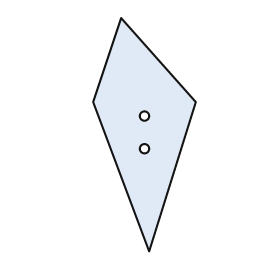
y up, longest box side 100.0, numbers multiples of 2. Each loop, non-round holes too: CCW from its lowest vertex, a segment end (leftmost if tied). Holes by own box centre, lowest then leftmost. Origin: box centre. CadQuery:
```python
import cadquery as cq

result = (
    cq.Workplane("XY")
    .moveTo(2.0, -50.0)
    .lineTo(22.0, 14.0)
    .lineTo(-10.0, 50.0)
    .lineTo(-22.0, 14.0)
    .close()
    .moveTo(0.0, -6.0)
    .circle(2.0)
    .moveTo(0.0, 8.0)
    .circle(2.0)
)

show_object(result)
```